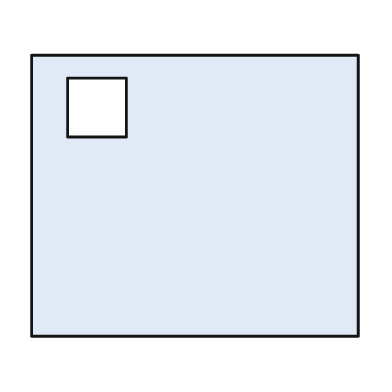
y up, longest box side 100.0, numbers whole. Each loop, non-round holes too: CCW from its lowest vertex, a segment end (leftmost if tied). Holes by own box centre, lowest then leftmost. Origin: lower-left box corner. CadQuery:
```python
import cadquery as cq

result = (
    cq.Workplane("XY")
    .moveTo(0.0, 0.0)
    .lineTo(100.0, 0.0)
    .lineTo(100.0, 86.0)
    .lineTo(0.0, 86.0)
    .close()
    .moveTo(11.0, 61.0)
    .lineTo(29.0, 61.0)
    .lineTo(29.0, 79.0)
    .lineTo(11.0, 79.0)
    .close()
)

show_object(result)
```